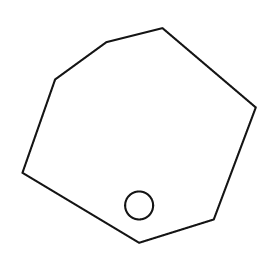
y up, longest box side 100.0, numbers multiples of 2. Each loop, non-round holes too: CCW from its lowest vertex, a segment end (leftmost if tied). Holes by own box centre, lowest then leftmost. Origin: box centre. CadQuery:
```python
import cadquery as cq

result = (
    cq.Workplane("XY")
    .moveTo(0.0, -46.0)
    .lineTo(32.0, -36.0)
    .lineTo(50.0, 12.0)
    .lineTo(10.0, 46.0)
    .lineTo(-14.0, 40.0)
    .lineTo(-36.0, 24.0)
    .lineTo(-50.0, -16.0)
    .close()
    .moveTo(0.0, -30.0)
    .circle(6.0)
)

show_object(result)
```